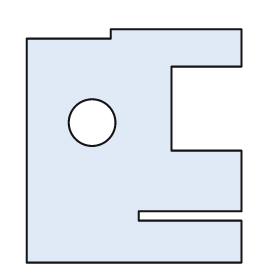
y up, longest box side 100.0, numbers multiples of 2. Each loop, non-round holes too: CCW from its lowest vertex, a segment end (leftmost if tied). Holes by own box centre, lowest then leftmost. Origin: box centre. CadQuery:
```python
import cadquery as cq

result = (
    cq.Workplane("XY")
    .moveTo(-46.0, -50.0)
    .lineTo(46.0, -50.0)
    .lineTo(46.0, -32.0)
    .lineTo(2.0, -32.0)
    .lineTo(2.0, -28.0)
    .lineTo(46.0, -28.0)
    .lineTo(46.0, -2.0)
    .lineTo(16.0, -2.0)
    .lineTo(16.0, 34.0)
    .lineTo(46.0, 34.0)
    .lineTo(46.0, 50.0)
    .lineTo(-10.0, 50.0)
    .lineTo(-10.0, 46.0)
    .lineTo(-46.0, 46.0)
    .close()
    .moveTo(-18.0, 10.0)
    .circle(10.0)
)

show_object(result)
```